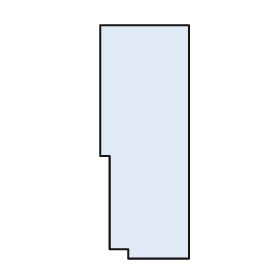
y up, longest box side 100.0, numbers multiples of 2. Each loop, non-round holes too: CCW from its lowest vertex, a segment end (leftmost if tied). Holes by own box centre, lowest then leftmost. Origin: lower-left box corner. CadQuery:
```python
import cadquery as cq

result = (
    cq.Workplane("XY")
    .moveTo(12.0, 0.0)
    .lineTo(38.0, 0.0)
    .lineTo(38.0, 100.0)
    .lineTo(0.0, 100.0)
    .lineTo(0.0, 44.0)
    .lineTo(4.0, 44.0)
    .lineTo(4.0, 4.0)
    .lineTo(12.0, 4.0)
    .close()
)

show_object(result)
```